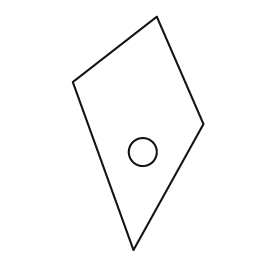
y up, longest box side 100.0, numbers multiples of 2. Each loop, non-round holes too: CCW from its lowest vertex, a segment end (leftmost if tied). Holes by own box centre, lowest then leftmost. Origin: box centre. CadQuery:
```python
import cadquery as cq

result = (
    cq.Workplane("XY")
    .moveTo(-2.0, -50.0)
    .lineTo(28.0, 4.0)
    .lineTo(8.0, 50.0)
    .lineTo(-28.0, 22.0)
    .close()
    .moveTo(2.0, -8.0)
    .circle(6.0)
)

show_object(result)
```